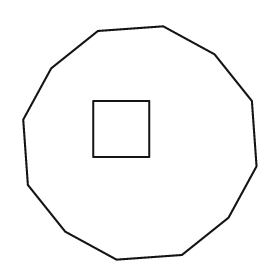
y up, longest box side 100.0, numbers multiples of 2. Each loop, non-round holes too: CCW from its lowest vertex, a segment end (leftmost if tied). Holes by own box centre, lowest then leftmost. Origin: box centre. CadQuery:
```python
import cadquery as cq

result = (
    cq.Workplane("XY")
    .moveTo(-10.0, -50.0)
    .lineTo(18.0, -48.0)
    .lineTo(38.0, -32.0)
    .lineTo(50.0, -10.0)
    .lineTo(48.0, 18.0)
    .lineTo(32.0, 38.0)
    .lineTo(10.0, 50.0)
    .lineTo(-18.0, 48.0)
    .lineTo(-38.0, 32.0)
    .lineTo(-50.0, 10.0)
    .lineTo(-48.0, -18.0)
    .lineTo(-32.0, -38.0)
    .close()
    .moveTo(-20.0, -6.0)
    .lineTo(4.0, -6.0)
    .lineTo(4.0, 18.0)
    .lineTo(-20.0, 18.0)
    .close()
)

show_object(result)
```